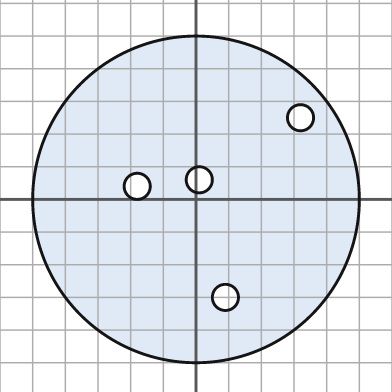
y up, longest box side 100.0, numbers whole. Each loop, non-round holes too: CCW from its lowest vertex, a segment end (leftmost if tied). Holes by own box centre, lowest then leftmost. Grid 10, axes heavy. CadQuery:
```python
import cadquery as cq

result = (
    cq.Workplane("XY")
    .moveTo(0.0, 0.0)
    .circle(50.0)
    .moveTo(9.0, -30.0)
    .circle(4.0)
    .moveTo(-18.0, 4.0)
    .circle(4.0)
    .moveTo(1.0, 6.0)
    .circle(4.0)
    .moveTo(32.0, 25.0)
    .circle(4.0)
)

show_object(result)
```